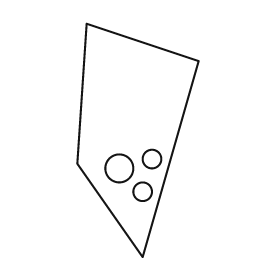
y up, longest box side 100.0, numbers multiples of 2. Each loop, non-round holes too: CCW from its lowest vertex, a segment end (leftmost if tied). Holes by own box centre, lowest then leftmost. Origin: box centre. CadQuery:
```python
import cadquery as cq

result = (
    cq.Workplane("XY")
    .moveTo(2.0, -50.0)
    .lineTo(26.0, 34.0)
    .lineTo(-22.0, 50.0)
    .lineTo(-26.0, -10.0)
    .close()
    .moveTo(2.0, -22.0)
    .circle(4.0)
    .moveTo(-8.0, -12.0)
    .circle(6.0)
    .moveTo(6.0, -8.0)
    .circle(4.0)
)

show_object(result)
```